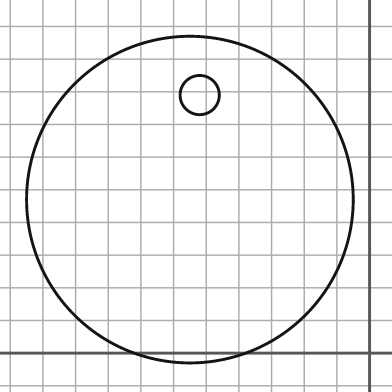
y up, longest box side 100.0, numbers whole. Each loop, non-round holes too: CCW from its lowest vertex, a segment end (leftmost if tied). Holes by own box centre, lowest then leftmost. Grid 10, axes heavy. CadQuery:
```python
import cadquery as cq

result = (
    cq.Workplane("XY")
    .moveTo(-55.0, 47.0)
    .circle(50.0)
    .moveTo(-52.0, 79.0)
    .circle(6.0)
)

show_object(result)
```